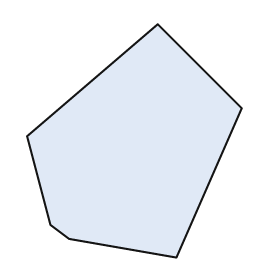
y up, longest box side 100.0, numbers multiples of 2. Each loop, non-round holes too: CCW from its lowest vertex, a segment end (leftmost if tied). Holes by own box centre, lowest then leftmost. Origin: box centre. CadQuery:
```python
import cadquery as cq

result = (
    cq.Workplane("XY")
    .moveTo(18.0, -50.0)
    .lineTo(46.0, 14.0)
    .lineTo(10.0, 50.0)
    .lineTo(-46.0, 2.0)
    .lineTo(-36.0, -36.0)
    .lineTo(-28.0, -42.0)
    .close()
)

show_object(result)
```